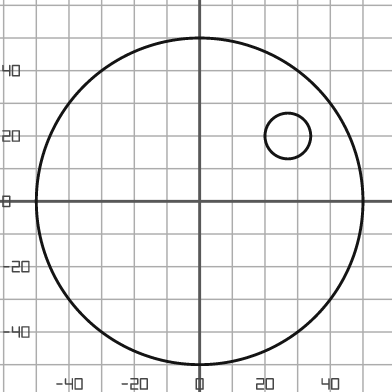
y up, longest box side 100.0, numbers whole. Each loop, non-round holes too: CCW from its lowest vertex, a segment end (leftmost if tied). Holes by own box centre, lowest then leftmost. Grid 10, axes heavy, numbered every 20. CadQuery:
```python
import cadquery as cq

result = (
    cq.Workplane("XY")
    .moveTo(0.0, 0.0)
    .circle(50.0)
    .moveTo(27.0, 20.0)
    .circle(7.0)
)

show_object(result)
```